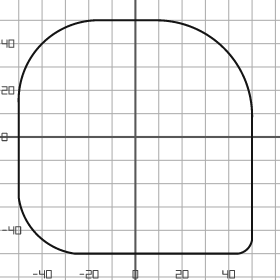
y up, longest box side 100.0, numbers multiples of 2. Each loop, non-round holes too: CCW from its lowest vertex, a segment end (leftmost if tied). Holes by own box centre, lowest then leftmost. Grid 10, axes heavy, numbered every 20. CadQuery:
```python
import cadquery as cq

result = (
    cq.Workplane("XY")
    .moveTo(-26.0, -50.0)
    .lineTo(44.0, -50.0)
    .threePointArc((48.0, -48.0), (50.0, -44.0))
    .lineTo(50.0, 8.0)
    .threePointArc((38.0, 38.0), (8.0, 50.0))
    .lineTo(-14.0, 50.0)
    .threePointArc((-40.0, 40.0), (-50.0, 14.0))
    .lineTo(-50.0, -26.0)
    .threePointArc((-42.0, -42.0), (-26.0, -50.0))
    .close()
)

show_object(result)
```